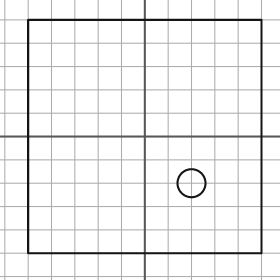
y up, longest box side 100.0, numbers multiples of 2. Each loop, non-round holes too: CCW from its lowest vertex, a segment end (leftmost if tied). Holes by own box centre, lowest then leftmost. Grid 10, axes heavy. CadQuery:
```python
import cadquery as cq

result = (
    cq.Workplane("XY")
    .moveTo(-50.0, -50.0)
    .lineTo(50.0, -50.0)
    .lineTo(50.0, 50.0)
    .lineTo(-50.0, 50.0)
    .close()
    .moveTo(20.0, -20.0)
    .circle(6.0)
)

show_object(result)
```